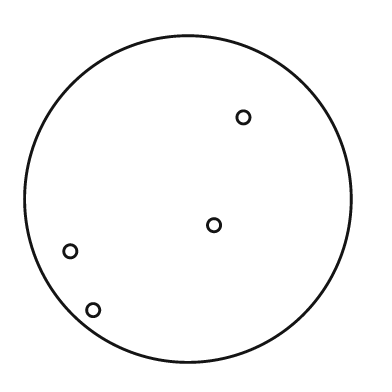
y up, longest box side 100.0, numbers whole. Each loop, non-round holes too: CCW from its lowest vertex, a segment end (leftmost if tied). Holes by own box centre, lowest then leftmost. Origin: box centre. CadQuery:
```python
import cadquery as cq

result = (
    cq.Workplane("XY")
    .moveTo(0.0, 0.0)
    .circle(50.0)
    .moveTo(-29.0, -34.0)
    .circle(2.0)
    .moveTo(-36.0, -16.0)
    .circle(2.0)
    .moveTo(8.0, -8.0)
    .circle(2.0)
    .moveTo(17.0, 25.0)
    .circle(2.0)
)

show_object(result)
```